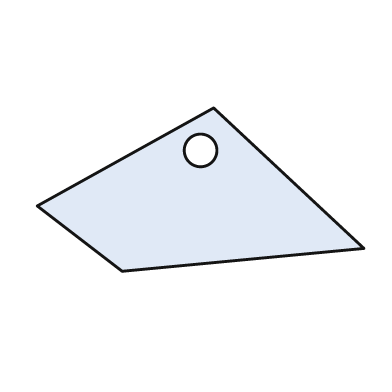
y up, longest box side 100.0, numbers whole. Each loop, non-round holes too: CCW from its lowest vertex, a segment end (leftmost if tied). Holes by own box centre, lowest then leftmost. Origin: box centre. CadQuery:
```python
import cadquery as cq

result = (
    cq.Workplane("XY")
    .moveTo(-24.0, -25.0)
    .lineTo(50.0, -18.0)
    .lineTo(4.0, 25.0)
    .lineTo(-50.0, -5.0)
    .close()
    .moveTo(0.0, 12.0)
    .circle(5.0)
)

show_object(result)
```